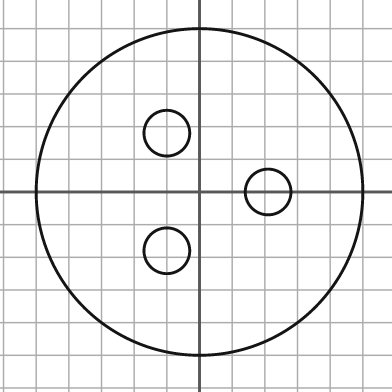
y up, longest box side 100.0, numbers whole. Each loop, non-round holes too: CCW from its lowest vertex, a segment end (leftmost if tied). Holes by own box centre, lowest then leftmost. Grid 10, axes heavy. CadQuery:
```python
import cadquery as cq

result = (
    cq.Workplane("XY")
    .moveTo(0.0, 0.0)
    .circle(50.0)
    .moveTo(-10.0, -18.0)
    .circle(7.0)
    .moveTo(21.0, 0.0)
    .circle(7.0)
    .moveTo(-10.0, 18.0)
    .circle(7.0)
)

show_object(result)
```